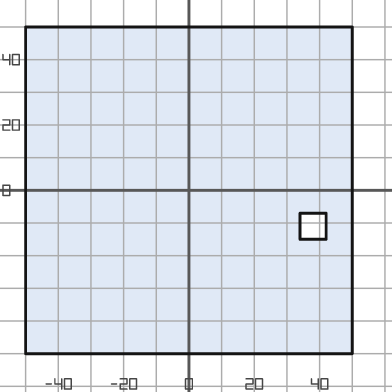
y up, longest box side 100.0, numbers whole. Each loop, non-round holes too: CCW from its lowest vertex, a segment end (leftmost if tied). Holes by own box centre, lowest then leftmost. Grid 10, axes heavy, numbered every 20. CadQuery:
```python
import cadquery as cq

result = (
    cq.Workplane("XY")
    .moveTo(-50.0, -50.0)
    .lineTo(50.0, -50.0)
    .lineTo(50.0, 50.0)
    .lineTo(-50.0, 50.0)
    .close()
    .moveTo(34.0, -15.0)
    .lineTo(42.0, -15.0)
    .lineTo(42.0, -7.0)
    .lineTo(34.0, -7.0)
    .close()
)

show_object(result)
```